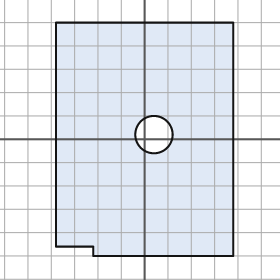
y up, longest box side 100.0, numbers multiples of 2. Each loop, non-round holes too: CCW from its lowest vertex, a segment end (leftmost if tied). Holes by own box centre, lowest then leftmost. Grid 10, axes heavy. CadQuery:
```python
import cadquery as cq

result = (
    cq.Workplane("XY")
    .moveTo(-22.0, -50.0)
    .lineTo(38.0, -50.0)
    .lineTo(38.0, 50.0)
    .lineTo(-38.0, 50.0)
    .lineTo(-38.0, -46.0)
    .lineTo(-22.0, -46.0)
    .close()
    .moveTo(4.0, 2.0)
    .circle(8.0)
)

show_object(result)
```